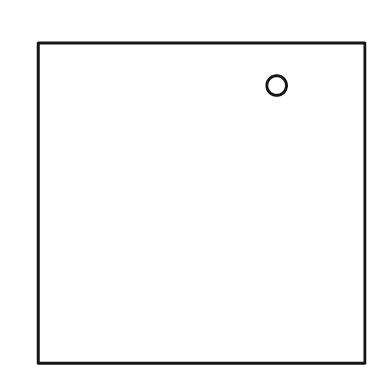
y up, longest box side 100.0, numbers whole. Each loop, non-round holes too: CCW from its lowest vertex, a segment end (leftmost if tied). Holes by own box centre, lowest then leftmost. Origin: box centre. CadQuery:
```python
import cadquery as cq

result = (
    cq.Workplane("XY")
    .moveTo(-50.0, -49.0)
    .lineTo(50.0, -49.0)
    .lineTo(50.0, 49.0)
    .lineTo(-50.0, 49.0)
    .close()
    .moveTo(23.0, 36.0)
    .circle(3.0)
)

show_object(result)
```